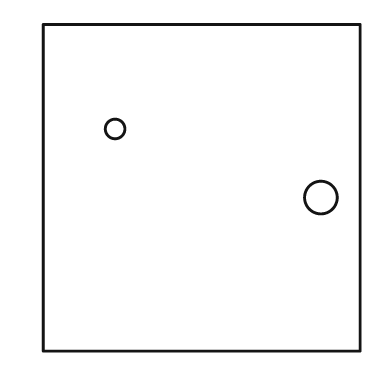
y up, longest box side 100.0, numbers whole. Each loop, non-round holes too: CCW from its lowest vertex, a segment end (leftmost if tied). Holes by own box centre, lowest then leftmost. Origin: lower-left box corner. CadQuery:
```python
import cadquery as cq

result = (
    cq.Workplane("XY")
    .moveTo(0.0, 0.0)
    .lineTo(97.0, 0.0)
    .lineTo(97.0, 100.0)
    .lineTo(0.0, 100.0)
    .close()
    .moveTo(85.0, 47.0)
    .circle(5.0)
    .moveTo(22.0, 68.0)
    .circle(3.0)
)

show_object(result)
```